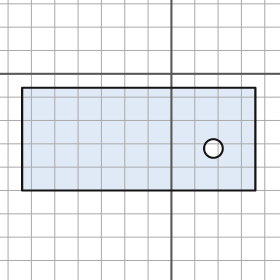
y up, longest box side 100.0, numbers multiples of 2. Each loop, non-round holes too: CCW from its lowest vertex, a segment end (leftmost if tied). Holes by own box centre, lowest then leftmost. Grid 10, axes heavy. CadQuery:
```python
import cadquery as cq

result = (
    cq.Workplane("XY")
    .moveTo(-64.0, -50.0)
    .lineTo(36.0, -50.0)
    .lineTo(36.0, -6.0)
    .lineTo(-64.0, -6.0)
    .close()
    .moveTo(18.0, -32.0)
    .circle(4.0)
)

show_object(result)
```